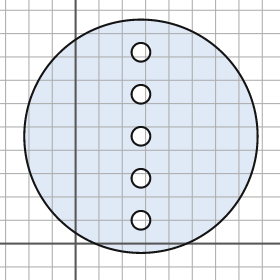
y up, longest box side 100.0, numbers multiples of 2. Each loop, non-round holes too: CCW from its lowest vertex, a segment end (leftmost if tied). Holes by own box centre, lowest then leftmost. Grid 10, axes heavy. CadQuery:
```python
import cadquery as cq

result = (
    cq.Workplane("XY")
    .moveTo(28.0, 46.0)
    .circle(50.0)
    .moveTo(28.0, 10.0)
    .circle(4.0)
    .moveTo(28.0, 28.0)
    .circle(4.0)
    .moveTo(28.0, 46.0)
    .circle(4.0)
    .moveTo(28.0, 64.0)
    .circle(4.0)
    .moveTo(28.0, 82.0)
    .circle(4.0)
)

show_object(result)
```